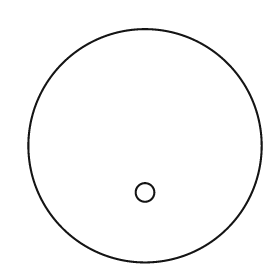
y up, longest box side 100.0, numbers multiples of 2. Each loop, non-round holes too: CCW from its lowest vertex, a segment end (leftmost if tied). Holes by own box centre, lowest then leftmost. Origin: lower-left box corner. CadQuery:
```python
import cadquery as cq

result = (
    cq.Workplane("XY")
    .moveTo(50.0, 50.0)
    .circle(50.0)
    .moveTo(50.0, 30.0)
    .circle(4.0)
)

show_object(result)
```